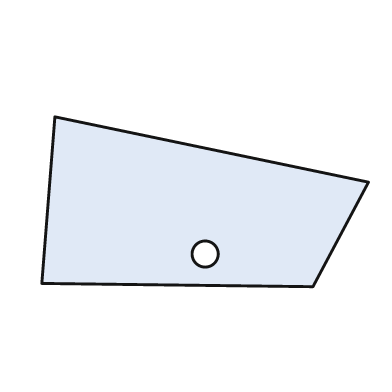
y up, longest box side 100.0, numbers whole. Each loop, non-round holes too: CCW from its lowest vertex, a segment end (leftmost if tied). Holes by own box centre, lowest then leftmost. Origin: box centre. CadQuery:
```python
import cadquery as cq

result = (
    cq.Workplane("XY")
    .moveTo(33.0, -26.0)
    .lineTo(50.0, 6.0)
    .lineTo(-46.0, 26.0)
    .lineTo(-50.0, -25.0)
    .close()
    .moveTo(0.0, -16.0)
    .circle(4.0)
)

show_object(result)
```